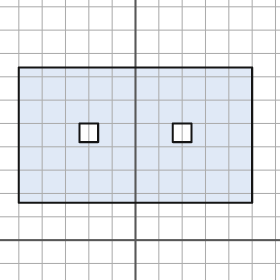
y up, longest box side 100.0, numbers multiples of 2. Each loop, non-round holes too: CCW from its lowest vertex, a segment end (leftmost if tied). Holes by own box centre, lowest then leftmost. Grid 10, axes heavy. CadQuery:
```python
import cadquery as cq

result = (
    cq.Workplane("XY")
    .moveTo(-50.0, 16.0)
    .lineTo(50.0, 16.0)
    .lineTo(50.0, 74.0)
    .lineTo(-50.0, 74.0)
    .close()
    .moveTo(-24.0, 42.0)
    .lineTo(-16.0, 42.0)
    .lineTo(-16.0, 50.0)
    .lineTo(-24.0, 50.0)
    .close()
    .moveTo(16.0, 42.0)
    .lineTo(24.0, 42.0)
    .lineTo(24.0, 50.0)
    .lineTo(16.0, 50.0)
    .close()
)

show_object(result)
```